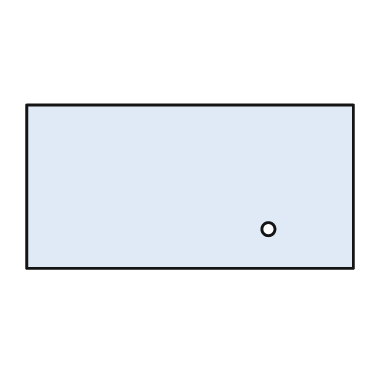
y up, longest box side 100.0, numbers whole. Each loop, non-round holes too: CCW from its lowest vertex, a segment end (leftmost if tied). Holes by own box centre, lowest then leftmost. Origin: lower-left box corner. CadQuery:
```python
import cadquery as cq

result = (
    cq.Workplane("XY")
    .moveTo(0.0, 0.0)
    .lineTo(100.0, 0.0)
    .lineTo(100.0, 50.0)
    .lineTo(0.0, 50.0)
    .close()
    .moveTo(74.0, 12.0)
    .circle(2.0)
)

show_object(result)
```